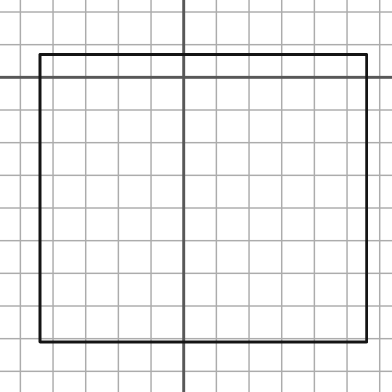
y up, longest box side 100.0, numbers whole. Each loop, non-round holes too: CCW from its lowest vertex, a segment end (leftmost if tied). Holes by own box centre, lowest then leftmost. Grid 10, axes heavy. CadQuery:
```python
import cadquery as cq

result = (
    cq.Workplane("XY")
    .moveTo(-44.0, -81.0)
    .lineTo(56.0, -81.0)
    .lineTo(56.0, 7.0)
    .lineTo(-44.0, 7.0)
    .close()
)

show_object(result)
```